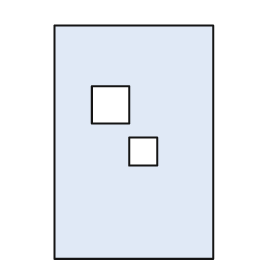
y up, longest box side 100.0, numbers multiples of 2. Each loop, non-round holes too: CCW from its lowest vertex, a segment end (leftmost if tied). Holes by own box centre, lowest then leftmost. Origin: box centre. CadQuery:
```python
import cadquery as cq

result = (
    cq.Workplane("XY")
    .moveTo(-34.0, -50.0)
    .lineTo(34.0, -50.0)
    .lineTo(34.0, 50.0)
    .lineTo(-34.0, 50.0)
    .close()
    .moveTo(-2.0, -10.0)
    .lineTo(10.0, -10.0)
    .lineTo(10.0, 2.0)
    .lineTo(-2.0, 2.0)
    .close()
    .moveTo(-18.0, 8.0)
    .lineTo(-2.0, 8.0)
    .lineTo(-2.0, 24.0)
    .lineTo(-18.0, 24.0)
    .close()
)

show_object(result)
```